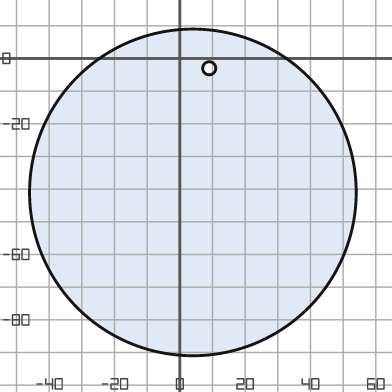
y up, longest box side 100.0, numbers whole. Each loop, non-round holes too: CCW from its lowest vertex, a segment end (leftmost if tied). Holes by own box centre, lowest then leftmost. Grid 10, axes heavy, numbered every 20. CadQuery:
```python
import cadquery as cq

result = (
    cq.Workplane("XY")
    .moveTo(4.0, -41.0)
    .circle(50.0)
    .moveTo(9.0, -3.0)
    .circle(2.0)
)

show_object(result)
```